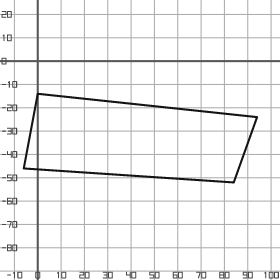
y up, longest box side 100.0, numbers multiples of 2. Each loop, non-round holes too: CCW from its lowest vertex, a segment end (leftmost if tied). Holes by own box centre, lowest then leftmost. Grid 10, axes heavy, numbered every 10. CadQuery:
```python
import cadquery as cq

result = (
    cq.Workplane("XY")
    .moveTo(84.0, -52.0)
    .lineTo(94.0, -24.0)
    .lineTo(0.0, -14.0)
    .lineTo(-6.0, -46.0)
    .close()
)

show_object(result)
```